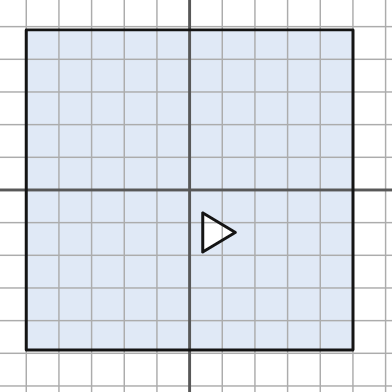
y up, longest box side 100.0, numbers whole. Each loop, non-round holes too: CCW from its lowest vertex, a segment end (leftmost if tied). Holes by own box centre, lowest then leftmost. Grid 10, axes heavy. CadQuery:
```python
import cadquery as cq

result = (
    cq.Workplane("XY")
    .moveTo(-50.0, -49.0)
    .lineTo(50.0, -49.0)
    .lineTo(50.0, 49.0)
    .lineTo(-50.0, 49.0)
    .close()
    .moveTo(4.0, -19.0)
    .lineTo(14.0, -13.0)
    .lineTo(4.0, -7.0)
    .close()
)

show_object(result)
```